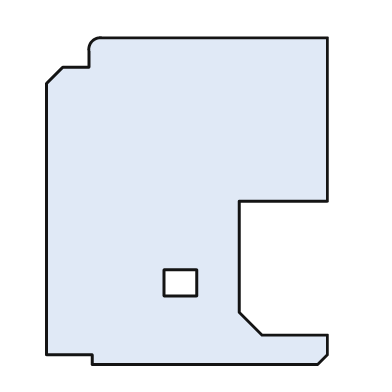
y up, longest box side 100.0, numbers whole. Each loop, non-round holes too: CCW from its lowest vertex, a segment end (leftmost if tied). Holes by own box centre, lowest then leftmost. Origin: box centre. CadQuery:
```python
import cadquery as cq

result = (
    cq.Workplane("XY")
    .moveTo(-29.0, -50.0)
    .lineTo(40.0, -50.0)
    .lineTo(43.0, -47.0)
    .lineTo(43.0, -41.0)
    .lineTo(23.0, -41.0)
    .lineTo(16.0, -34.0)
    .lineTo(16.0, 0.0)
    .lineTo(43.0, 0.0)
    .lineTo(43.0, 50.0)
    .lineTo(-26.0, 50.0)
    .threePointArc((-29.0, 49.0), (-30.0, 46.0))
    .lineTo(-30.0, 41.0)
    .lineTo(-38.0, 41.0)
    .lineTo(-43.0, 36.0)
    .lineTo(-43.0, -47.0)
    .lineTo(-29.0, -47.0)
    .close()
    .moveTo(-7.0, -29.0)
    .lineTo(3.0, -29.0)
    .lineTo(3.0, -21.0)
    .lineTo(-7.0, -21.0)
    .close()
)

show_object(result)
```